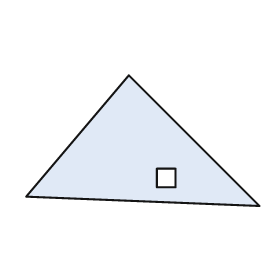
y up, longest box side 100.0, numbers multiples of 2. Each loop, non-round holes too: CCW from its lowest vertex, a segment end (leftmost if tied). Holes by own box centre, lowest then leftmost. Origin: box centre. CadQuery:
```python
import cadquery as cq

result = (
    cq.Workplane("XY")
    .moveTo(50.0, -28.0)
    .lineTo(-6.0, 28.0)
    .lineTo(-50.0, -24.0)
    .close()
    .moveTo(6.0, -20.0)
    .lineTo(14.0, -20.0)
    .lineTo(14.0, -12.0)
    .lineTo(6.0, -12.0)
    .close()
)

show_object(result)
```